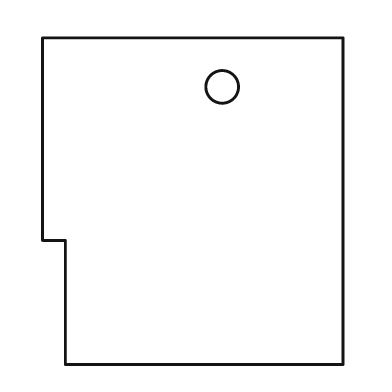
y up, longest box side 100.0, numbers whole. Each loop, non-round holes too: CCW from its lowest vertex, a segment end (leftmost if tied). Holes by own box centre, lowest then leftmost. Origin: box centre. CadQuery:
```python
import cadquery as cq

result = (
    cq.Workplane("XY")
    .moveTo(-39.0, -50.0)
    .lineTo(46.0, -50.0)
    .lineTo(46.0, 50.0)
    .lineTo(-46.0, 50.0)
    .lineTo(-46.0, -12.0)
    .lineTo(-39.0, -12.0)
    .close()
    .moveTo(9.0, 35.0)
    .circle(5.0)
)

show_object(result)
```